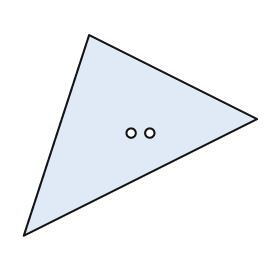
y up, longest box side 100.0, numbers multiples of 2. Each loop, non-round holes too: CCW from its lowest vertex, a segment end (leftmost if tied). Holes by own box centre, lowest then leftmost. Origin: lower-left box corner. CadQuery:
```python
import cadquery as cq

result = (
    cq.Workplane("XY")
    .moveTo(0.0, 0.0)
    .lineTo(100.0, 50.0)
    .lineTo(28.0, 86.0)
    .close()
    .moveTo(46.0, 44.0)
    .circle(2.0)
    .moveTo(54.0, 44.0)
    .circle(2.0)
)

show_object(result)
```